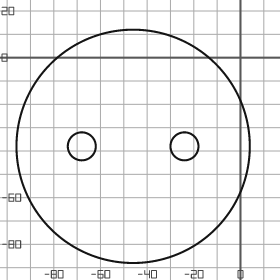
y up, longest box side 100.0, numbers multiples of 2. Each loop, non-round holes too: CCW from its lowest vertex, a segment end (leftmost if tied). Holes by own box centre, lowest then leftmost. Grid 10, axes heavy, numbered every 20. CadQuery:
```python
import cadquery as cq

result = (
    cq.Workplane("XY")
    .moveTo(-46.0, -38.0)
    .circle(50.0)
    .moveTo(-68.0, -38.0)
    .circle(6.0)
    .moveTo(-24.0, -38.0)
    .circle(6.0)
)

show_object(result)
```